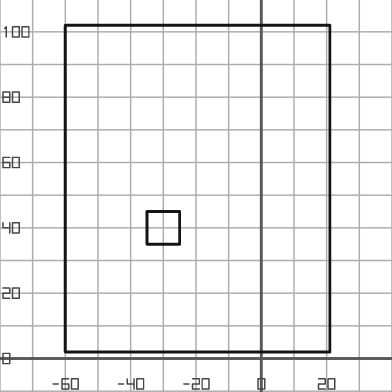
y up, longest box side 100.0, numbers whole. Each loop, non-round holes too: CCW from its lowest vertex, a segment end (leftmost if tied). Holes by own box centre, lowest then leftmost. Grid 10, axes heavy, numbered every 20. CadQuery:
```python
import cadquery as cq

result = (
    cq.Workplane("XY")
    .moveTo(-60.0, 2.0)
    .lineTo(21.0, 2.0)
    .lineTo(21.0, 102.0)
    .lineTo(-60.0, 102.0)
    .close()
    .moveTo(-35.0, 35.0)
    .lineTo(-25.0, 35.0)
    .lineTo(-25.0, 45.0)
    .lineTo(-35.0, 45.0)
    .close()
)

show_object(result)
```